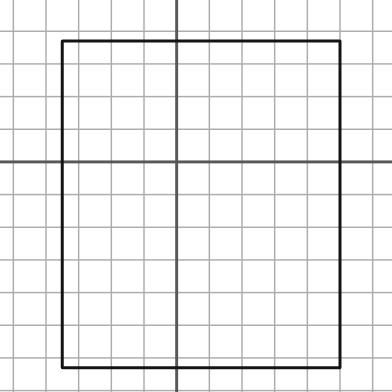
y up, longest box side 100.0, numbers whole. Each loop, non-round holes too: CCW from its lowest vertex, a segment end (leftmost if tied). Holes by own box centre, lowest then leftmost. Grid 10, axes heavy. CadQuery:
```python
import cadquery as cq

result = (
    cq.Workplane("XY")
    .moveTo(-35.0, -63.0)
    .lineTo(50.0, -63.0)
    .lineTo(50.0, 37.0)
    .lineTo(-35.0, 37.0)
    .close()
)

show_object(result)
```